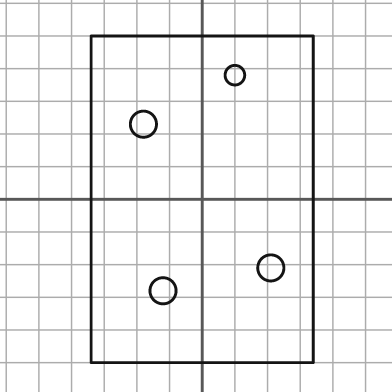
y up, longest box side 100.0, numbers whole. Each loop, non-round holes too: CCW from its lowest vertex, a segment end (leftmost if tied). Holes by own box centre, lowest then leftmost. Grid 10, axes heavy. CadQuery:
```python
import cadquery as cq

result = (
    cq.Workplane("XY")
    .moveTo(-34.0, -50.0)
    .lineTo(34.0, -50.0)
    .lineTo(34.0, 50.0)
    .lineTo(-34.0, 50.0)
    .close()
    .moveTo(-12.0, -28.0)
    .circle(4.0)
    .moveTo(21.0, -21.0)
    .circle(4.0)
    .moveTo(-18.0, 23.0)
    .circle(4.0)
    .moveTo(10.0, 38.0)
    .circle(3.0)
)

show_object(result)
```